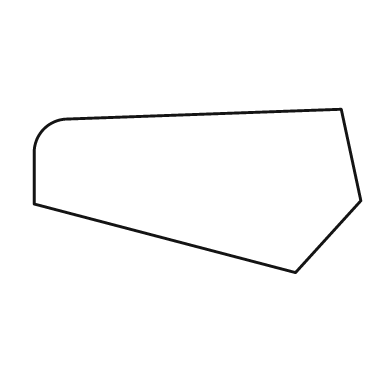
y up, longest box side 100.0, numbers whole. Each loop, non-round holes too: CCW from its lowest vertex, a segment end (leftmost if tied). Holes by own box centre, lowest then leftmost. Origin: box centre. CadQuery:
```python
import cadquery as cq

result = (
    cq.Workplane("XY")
    .moveTo(30.0, -25.0)
    .lineTo(50.0, -3.0)
    .lineTo(44.0, 25.0)
    .lineTo(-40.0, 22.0)
    .threePointArc((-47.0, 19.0), (-50.0, 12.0))
    .lineTo(-50.0, -4.0)
    .close()
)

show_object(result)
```